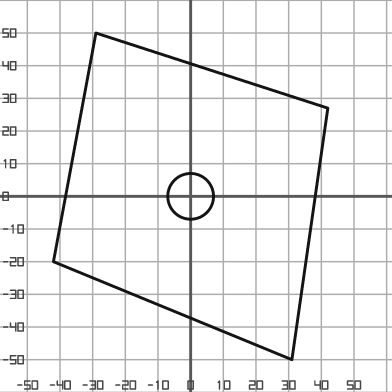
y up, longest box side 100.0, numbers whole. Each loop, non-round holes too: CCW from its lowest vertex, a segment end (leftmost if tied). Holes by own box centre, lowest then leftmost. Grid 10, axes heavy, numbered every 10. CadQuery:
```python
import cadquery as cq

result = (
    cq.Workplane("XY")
    .moveTo(31.0, -50.0)
    .lineTo(42.0, 27.0)
    .lineTo(-29.0, 50.0)
    .lineTo(-42.0, -20.0)
    .close()
    .moveTo(0.0, 0.0)
    .circle(7.0)
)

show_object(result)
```